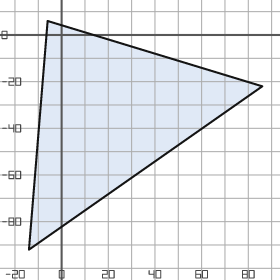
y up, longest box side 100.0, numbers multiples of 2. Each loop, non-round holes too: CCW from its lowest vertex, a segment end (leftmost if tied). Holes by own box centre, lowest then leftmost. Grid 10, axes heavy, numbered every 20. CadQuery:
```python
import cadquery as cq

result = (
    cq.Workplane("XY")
    .moveTo(-14.0, -92.0)
    .lineTo(86.0, -22.0)
    .lineTo(-6.0, 6.0)
    .close()
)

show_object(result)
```